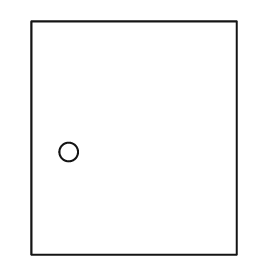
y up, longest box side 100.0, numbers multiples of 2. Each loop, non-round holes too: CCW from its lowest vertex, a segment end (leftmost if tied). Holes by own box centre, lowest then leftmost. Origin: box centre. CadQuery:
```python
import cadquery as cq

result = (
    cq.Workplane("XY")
    .moveTo(-44.0, -50.0)
    .lineTo(44.0, -50.0)
    .lineTo(44.0, 50.0)
    .lineTo(-44.0, 50.0)
    .close()
    .moveTo(-28.0, -6.0)
    .circle(4.0)
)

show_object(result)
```